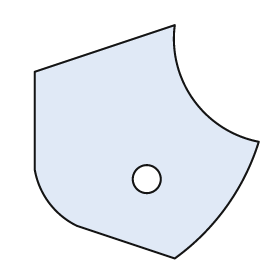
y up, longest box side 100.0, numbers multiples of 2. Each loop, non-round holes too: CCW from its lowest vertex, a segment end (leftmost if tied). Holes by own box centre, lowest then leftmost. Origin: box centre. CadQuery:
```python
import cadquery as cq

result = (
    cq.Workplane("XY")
    .moveTo(12.0, -50.0)
    .threePointArc((34.0, -28.0), (48.0, 0.0))
    .threePointArc((20.0, 18.0), (12.0, 50.0))
    .lineTo(-48.0, 30.0)
    .lineTo(-48.0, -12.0)
    .threePointArc((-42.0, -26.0), (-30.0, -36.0))
    .close()
    .moveTo(0.0, -16.0)
    .circle(6.0)
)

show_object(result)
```